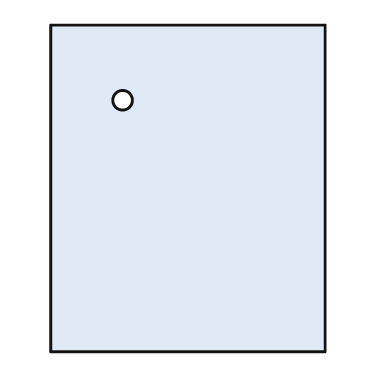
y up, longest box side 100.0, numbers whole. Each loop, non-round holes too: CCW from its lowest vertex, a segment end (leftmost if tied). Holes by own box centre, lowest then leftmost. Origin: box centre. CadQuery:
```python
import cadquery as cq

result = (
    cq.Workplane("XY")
    .moveTo(-42.0, -50.0)
    .lineTo(42.0, -50.0)
    .lineTo(42.0, 50.0)
    .lineTo(-42.0, 50.0)
    .close()
    .moveTo(-20.0, 27.0)
    .circle(3.0)
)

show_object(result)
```